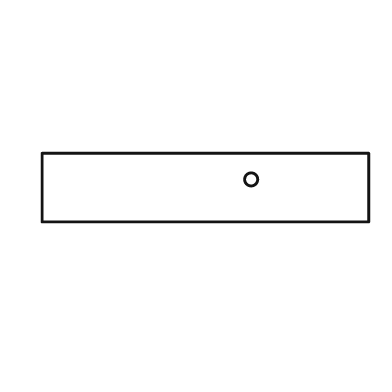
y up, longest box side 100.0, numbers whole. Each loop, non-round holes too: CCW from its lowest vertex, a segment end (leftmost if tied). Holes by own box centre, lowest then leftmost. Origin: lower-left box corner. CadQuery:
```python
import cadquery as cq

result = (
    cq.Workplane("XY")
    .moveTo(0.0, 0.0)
    .lineTo(100.0, 0.0)
    .lineTo(100.0, 21.0)
    .lineTo(0.0, 21.0)
    .close()
    .moveTo(64.0, 13.0)
    .circle(2.0)
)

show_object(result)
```